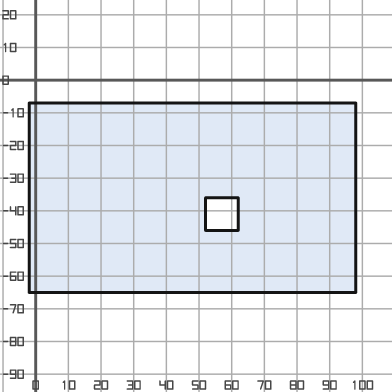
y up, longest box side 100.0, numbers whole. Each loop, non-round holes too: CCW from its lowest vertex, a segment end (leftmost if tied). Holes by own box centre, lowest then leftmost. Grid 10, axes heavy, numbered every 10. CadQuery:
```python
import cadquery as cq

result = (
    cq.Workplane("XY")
    .moveTo(-2.0, -65.0)
    .lineTo(98.0, -65.0)
    .lineTo(98.0, -7.0)
    .lineTo(-2.0, -7.0)
    .close()
    .moveTo(52.0, -46.0)
    .lineTo(62.0, -46.0)
    .lineTo(62.0, -36.0)
    .lineTo(52.0, -36.0)
    .close()
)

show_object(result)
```